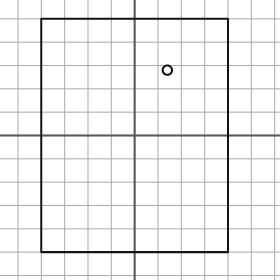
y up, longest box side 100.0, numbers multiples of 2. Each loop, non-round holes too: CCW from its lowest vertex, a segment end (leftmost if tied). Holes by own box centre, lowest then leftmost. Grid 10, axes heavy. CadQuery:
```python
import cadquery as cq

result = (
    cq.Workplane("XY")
    .moveTo(-40.0, -50.0)
    .lineTo(40.0, -50.0)
    .lineTo(40.0, 50.0)
    .lineTo(-40.0, 50.0)
    .close()
    .moveTo(14.0, 28.0)
    .circle(2.0)
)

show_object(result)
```